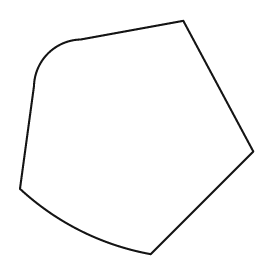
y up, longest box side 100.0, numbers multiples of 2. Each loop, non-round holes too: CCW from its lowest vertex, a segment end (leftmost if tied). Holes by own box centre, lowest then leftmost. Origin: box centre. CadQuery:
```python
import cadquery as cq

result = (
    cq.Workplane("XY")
    .moveTo(6.0, -50.0)
    .lineTo(50.0, -6.0)
    .lineTo(20.0, 50.0)
    .lineTo(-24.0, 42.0)
    .threePointArc((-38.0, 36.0), (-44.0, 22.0))
    .lineTo(-50.0, -22.0)
    .threePointArc((-24.0, -40.0), (6.0, -50.0))
    .close()
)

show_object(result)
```